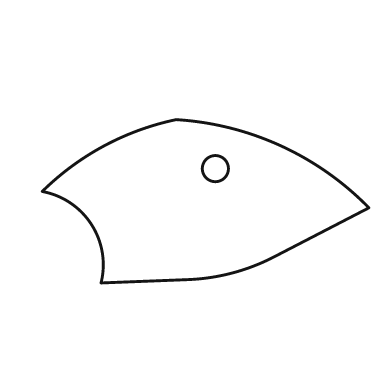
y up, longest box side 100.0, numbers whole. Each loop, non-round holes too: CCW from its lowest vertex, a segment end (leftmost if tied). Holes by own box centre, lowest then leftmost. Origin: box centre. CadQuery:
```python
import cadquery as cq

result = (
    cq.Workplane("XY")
    .moveTo(-32.0, -25.0)
    .lineTo(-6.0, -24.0)
    .threePointArc((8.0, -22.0), (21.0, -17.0))
    .lineTo(50.0, -2.0)
    .threePointArc((23.0, 17.0), (-9.0, 25.0))
    .threePointArc((-31.0, 17.0), (-50.0, 3.0))
    .threePointArc((-35.0, -7.0), (-32.0, -25.0))
    .close()
    .moveTo(3.0, 10.0)
    .circle(4.0)
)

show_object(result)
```